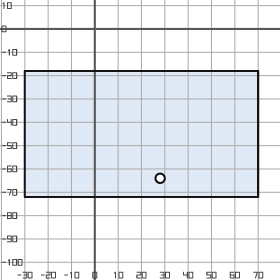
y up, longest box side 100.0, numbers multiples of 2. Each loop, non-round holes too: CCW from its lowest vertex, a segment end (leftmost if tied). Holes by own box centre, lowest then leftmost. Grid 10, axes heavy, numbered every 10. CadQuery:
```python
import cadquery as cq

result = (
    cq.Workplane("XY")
    .moveTo(-30.0, -72.0)
    .lineTo(70.0, -72.0)
    .lineTo(70.0, -18.0)
    .lineTo(-30.0, -18.0)
    .close()
    .moveTo(28.0, -64.0)
    .circle(2.0)
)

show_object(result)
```